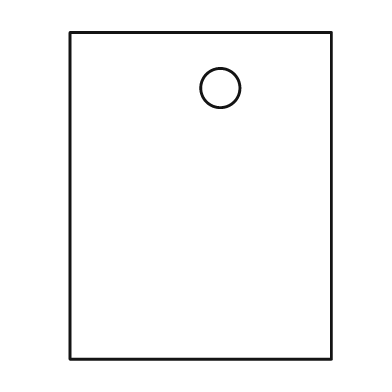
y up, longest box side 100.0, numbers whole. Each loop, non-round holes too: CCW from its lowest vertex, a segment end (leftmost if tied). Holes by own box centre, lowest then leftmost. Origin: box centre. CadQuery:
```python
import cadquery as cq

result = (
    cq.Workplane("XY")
    .moveTo(-40.0, -50.0)
    .lineTo(40.0, -50.0)
    .lineTo(40.0, 50.0)
    .lineTo(-40.0, 50.0)
    .close()
    .moveTo(6.0, 33.0)
    .circle(6.0)
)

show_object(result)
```